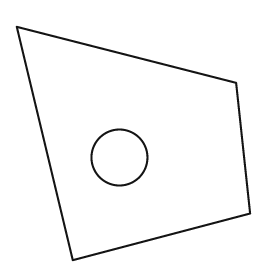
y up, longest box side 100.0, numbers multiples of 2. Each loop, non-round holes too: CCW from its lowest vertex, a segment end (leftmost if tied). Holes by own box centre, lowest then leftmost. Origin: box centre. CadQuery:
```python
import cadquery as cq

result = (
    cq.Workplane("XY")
    .moveTo(-26.0, -50.0)
    .lineTo(50.0, -30.0)
    .lineTo(44.0, 26.0)
    .lineTo(-50.0, 50.0)
    .close()
    .moveTo(-6.0, -6.0)
    .circle(12.0)
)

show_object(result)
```